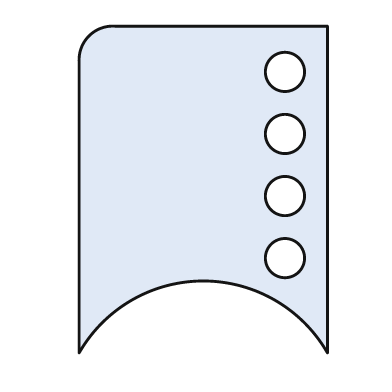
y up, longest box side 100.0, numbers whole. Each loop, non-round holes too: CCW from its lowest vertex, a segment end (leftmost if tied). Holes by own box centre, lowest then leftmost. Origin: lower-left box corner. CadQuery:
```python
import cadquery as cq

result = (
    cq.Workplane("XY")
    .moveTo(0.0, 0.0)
    .threePointArc((38.0, 22.0), (76.0, 0.0))
    .lineTo(76.0, 100.0)
    .lineTo(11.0, 100.0)
    .threePointArc((3.0, 97.0), (0.0, 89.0))
    .close()
    .moveTo(63.0, 29.0)
    .circle(6.0)
    .moveTo(63.0, 48.0)
    .circle(6.0)
    .moveTo(63.0, 67.0)
    .circle(6.0)
    .moveTo(63.0, 86.0)
    .circle(6.0)
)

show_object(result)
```